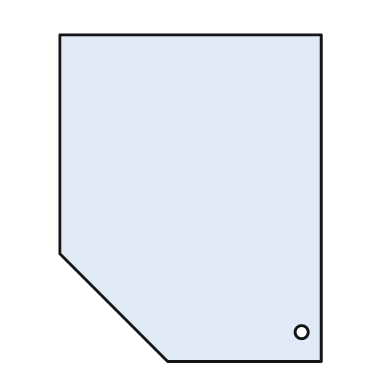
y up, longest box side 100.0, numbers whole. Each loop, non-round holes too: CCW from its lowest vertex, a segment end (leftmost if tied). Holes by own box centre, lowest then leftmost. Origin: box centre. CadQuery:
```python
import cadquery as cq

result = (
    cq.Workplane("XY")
    .moveTo(-7.0, -50.0)
    .lineTo(40.0, -50.0)
    .lineTo(40.0, 50.0)
    .lineTo(-40.0, 50.0)
    .lineTo(-40.0, -17.0)
    .close()
    .moveTo(34.0, -41.0)
    .circle(2.0)
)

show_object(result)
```